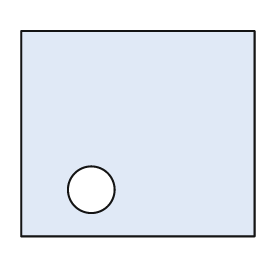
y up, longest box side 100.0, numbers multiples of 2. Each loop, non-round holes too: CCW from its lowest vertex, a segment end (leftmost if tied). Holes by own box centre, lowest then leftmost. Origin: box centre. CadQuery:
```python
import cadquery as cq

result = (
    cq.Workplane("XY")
    .moveTo(-50.0, -44.0)
    .lineTo(50.0, -44.0)
    .lineTo(50.0, 44.0)
    .lineTo(-50.0, 44.0)
    .close()
    .moveTo(-20.0, -24.0)
    .circle(10.0)
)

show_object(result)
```